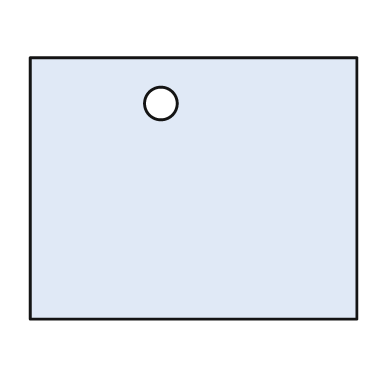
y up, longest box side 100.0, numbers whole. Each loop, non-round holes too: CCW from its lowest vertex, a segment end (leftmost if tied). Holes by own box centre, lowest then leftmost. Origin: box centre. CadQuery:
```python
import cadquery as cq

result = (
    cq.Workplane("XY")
    .moveTo(-50.0, -40.0)
    .lineTo(50.0, -40.0)
    .lineTo(50.0, 40.0)
    .lineTo(-50.0, 40.0)
    .close()
    .moveTo(-10.0, 26.0)
    .circle(5.0)
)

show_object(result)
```